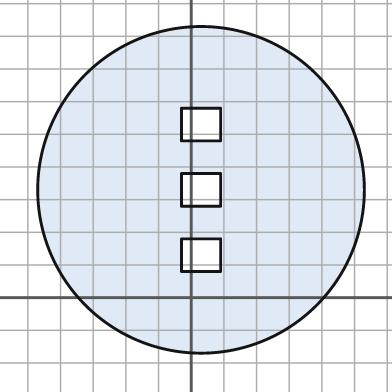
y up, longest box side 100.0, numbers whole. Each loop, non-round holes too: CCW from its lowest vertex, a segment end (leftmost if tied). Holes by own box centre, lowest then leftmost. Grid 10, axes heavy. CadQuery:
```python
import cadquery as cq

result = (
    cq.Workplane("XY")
    .moveTo(3.0, 33.0)
    .circle(50.0)
    .moveTo(-3.0, 8.0)
    .lineTo(9.0, 8.0)
    .lineTo(9.0, 18.0)
    .lineTo(-3.0, 18.0)
    .close()
    .moveTo(-3.0, 28.0)
    .lineTo(9.0, 28.0)
    .lineTo(9.0, 38.0)
    .lineTo(-3.0, 38.0)
    .close()
    .moveTo(-3.0, 48.0)
    .lineTo(9.0, 48.0)
    .lineTo(9.0, 58.0)
    .lineTo(-3.0, 58.0)
    .close()
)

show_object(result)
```